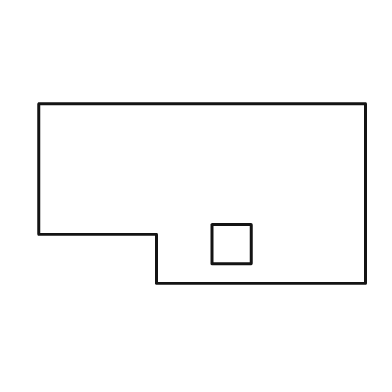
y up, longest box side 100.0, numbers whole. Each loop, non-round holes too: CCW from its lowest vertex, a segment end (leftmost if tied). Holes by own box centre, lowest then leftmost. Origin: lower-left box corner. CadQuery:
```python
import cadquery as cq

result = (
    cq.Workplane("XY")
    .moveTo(36.0, 0.0)
    .lineTo(100.0, 0.0)
    .lineTo(100.0, 55.0)
    .lineTo(0.0, 55.0)
    .lineTo(0.0, 15.0)
    .lineTo(36.0, 15.0)
    .close()
    .moveTo(53.0, 6.0)
    .lineTo(65.0, 6.0)
    .lineTo(65.0, 18.0)
    .lineTo(53.0, 18.0)
    .close()
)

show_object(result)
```